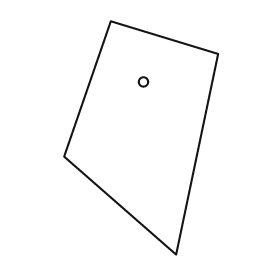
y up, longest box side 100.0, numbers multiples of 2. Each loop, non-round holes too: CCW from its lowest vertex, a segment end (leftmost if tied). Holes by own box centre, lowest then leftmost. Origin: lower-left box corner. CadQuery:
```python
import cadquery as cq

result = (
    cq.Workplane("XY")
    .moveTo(48.0, 0.0)
    .lineTo(66.0, 86.0)
    .lineTo(20.0, 100.0)
    .lineTo(0.0, 42.0)
    .close()
    .moveTo(34.0, 74.0)
    .circle(2.0)
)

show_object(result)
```